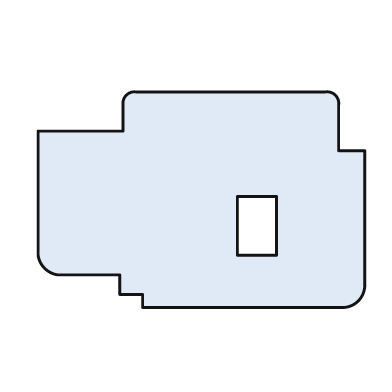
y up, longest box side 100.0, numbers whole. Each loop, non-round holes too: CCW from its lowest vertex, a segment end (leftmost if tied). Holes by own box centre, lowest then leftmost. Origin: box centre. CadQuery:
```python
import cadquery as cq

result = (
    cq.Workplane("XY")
    .moveTo(-18.0, -33.0)
    .lineTo(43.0, -33.0)
    .threePointArc((48.0, -31.0), (50.0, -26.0))
    .lineTo(50.0, 15.0)
    .lineTo(42.0, 15.0)
    .lineTo(42.0, 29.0)
    .threePointArc((41.0, 32.0), (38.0, 33.0))
    .lineTo(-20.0, 33.0)
    .threePointArc((-23.0, 32.0), (-24.0, 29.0))
    .lineTo(-24.0, 21.0)
    .lineTo(-50.0, 21.0)
    .lineTo(-50.0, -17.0)
    .threePointArc((-48.0, -21.0), (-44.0, -23.0))
    .lineTo(-25.0, -23.0)
    .lineTo(-25.0, -29.0)
    .lineTo(-18.0, -29.0)
    .close()
    .moveTo(11.0, -17.0)
    .lineTo(23.0, -17.0)
    .lineTo(23.0, 1.0)
    .lineTo(11.0, 1.0)
    .close()
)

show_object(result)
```